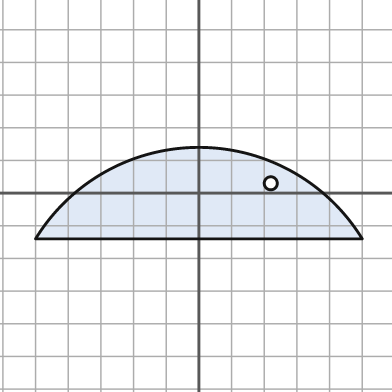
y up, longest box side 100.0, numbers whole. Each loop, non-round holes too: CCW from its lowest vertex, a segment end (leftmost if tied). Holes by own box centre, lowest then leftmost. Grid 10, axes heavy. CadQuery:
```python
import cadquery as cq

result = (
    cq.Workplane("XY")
    .moveTo(-50.0, -14.0)
    .lineTo(50.0, -14.0)
    .threePointArc((0.0, 14.0), (-50.0, -14.0))
    .close()
    .moveTo(22.0, 3.0)
    .circle(2.0)
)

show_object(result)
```